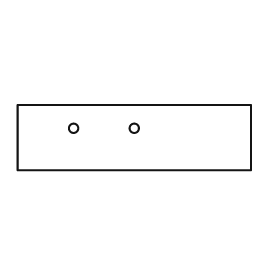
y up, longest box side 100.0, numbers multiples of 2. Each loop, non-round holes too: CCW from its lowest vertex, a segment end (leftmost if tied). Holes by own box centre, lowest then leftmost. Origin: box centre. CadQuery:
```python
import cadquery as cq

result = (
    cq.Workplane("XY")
    .moveTo(-50.0, -14.0)
    .lineTo(50.0, -14.0)
    .lineTo(50.0, 14.0)
    .lineTo(-50.0, 14.0)
    .close()
    .moveTo(-26.0, 4.0)
    .circle(2.0)
    .moveTo(0.0, 4.0)
    .circle(2.0)
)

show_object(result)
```